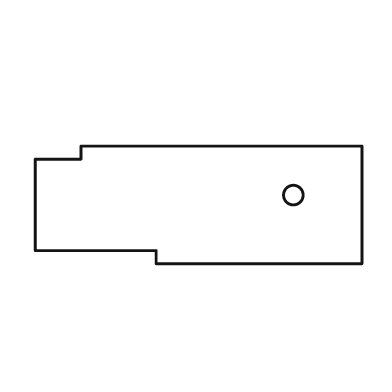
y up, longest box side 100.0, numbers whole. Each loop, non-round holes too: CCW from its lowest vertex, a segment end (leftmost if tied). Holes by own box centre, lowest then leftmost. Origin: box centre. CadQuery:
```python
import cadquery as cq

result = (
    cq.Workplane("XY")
    .moveTo(-13.0, -18.0)
    .lineTo(50.0, -18.0)
    .lineTo(50.0, 18.0)
    .lineTo(-36.0, 18.0)
    .lineTo(-36.0, 14.0)
    .lineTo(-50.0, 14.0)
    .lineTo(-50.0, -14.0)
    .lineTo(-13.0, -14.0)
    .close()
    .moveTo(29.0, 3.0)
    .circle(3.0)
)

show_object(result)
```